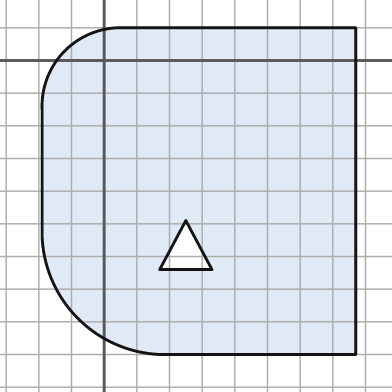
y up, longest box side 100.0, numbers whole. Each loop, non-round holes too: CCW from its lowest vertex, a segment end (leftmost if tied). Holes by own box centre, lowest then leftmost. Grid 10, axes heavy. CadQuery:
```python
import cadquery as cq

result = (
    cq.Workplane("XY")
    .moveTo(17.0, -90.0)
    .lineTo(77.0, -90.0)
    .lineTo(77.0, 10.0)
    .lineTo(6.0, 10.0)
    .threePointArc((-12.0, 3.0), (-19.0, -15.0))
    .lineTo(-19.0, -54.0)
    .threePointArc((-8.0, -79.0), (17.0, -90.0))
    .close()
    .moveTo(17.0, -64.0)
    .lineTo(33.0, -64.0)
    .lineTo(25.0, -49.0)
    .close()
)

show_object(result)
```